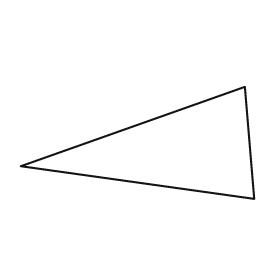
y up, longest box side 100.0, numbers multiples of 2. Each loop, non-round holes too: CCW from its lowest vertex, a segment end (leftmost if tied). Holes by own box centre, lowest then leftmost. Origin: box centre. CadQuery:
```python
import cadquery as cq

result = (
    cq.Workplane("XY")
    .moveTo(50.0, -24.0)
    .lineTo(46.0, 24.0)
    .lineTo(-50.0, -10.0)
    .close()
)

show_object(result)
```